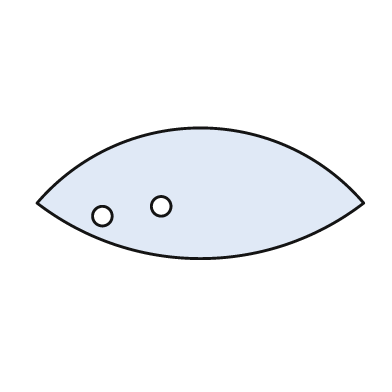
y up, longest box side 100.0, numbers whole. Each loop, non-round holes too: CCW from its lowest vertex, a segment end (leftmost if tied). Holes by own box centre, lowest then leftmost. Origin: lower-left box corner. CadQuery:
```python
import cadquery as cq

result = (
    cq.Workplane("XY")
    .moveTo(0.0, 17.0)
    .threePointArc((50.0, 0.0), (100.0, 17.0))
    .threePointArc((50.0, 40.0), (0.0, 17.0))
    .close()
    .moveTo(20.0, 13.0)
    .circle(3.0)
    .moveTo(38.0, 16.0)
    .circle(3.0)
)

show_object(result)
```